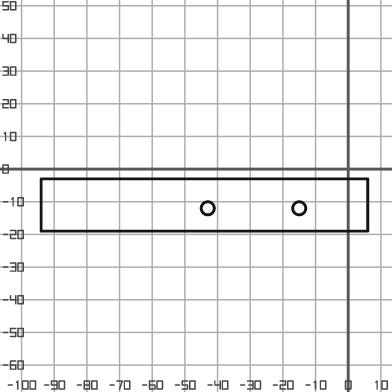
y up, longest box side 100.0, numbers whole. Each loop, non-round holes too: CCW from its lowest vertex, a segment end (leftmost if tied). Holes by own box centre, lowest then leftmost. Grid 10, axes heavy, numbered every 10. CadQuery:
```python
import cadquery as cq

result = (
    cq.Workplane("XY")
    .moveTo(-94.0, -19.0)
    .lineTo(6.0, -19.0)
    .lineTo(6.0, -3.0)
    .lineTo(-94.0, -3.0)
    .close()
    .moveTo(-43.0, -12.0)
    .circle(2.0)
    .moveTo(-15.0, -12.0)
    .circle(2.0)
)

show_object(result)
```